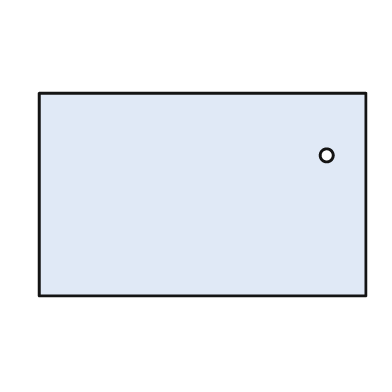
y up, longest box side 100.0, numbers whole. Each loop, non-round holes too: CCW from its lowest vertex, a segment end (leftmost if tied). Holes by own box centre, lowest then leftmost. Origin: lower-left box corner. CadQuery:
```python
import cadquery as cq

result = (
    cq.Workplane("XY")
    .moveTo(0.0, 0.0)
    .lineTo(100.0, 0.0)
    .lineTo(100.0, 62.0)
    .lineTo(0.0, 62.0)
    .close()
    .moveTo(88.0, 43.0)
    .circle(2.0)
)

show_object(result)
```